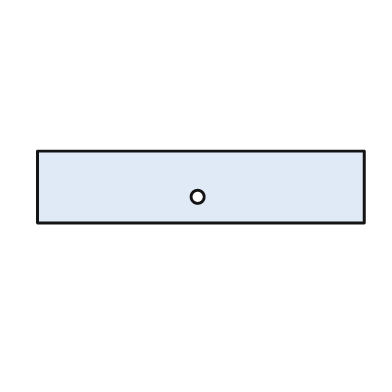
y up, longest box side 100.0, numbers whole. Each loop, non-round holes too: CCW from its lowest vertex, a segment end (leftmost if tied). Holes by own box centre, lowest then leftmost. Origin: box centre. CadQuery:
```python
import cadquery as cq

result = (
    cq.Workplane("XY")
    .moveTo(-50.0, -11.0)
    .lineTo(50.0, -11.0)
    .lineTo(50.0, 11.0)
    .lineTo(-50.0, 11.0)
    .close()
    .moveTo(-1.0, -3.0)
    .circle(2.0)
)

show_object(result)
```